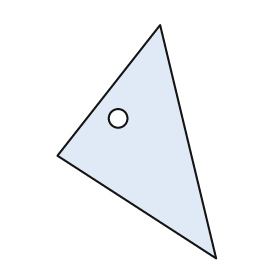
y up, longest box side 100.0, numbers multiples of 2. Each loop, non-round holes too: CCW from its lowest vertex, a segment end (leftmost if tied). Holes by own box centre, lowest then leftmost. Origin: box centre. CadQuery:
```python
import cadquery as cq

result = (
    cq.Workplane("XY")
    .moveTo(34.0, -50.0)
    .lineTo(10.0, 50.0)
    .lineTo(-34.0, -6.0)
    .close()
    .moveTo(-8.0, 10.0)
    .circle(4.0)
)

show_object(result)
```